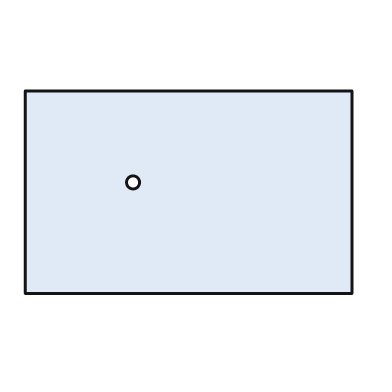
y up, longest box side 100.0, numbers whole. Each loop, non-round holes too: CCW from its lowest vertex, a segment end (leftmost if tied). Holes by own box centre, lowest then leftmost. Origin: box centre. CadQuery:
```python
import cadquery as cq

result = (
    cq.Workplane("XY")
    .moveTo(-50.0, -31.0)
    .lineTo(50.0, -31.0)
    .lineTo(50.0, 31.0)
    .lineTo(-50.0, 31.0)
    .close()
    .moveTo(-17.0, 3.0)
    .circle(2.0)
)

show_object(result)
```